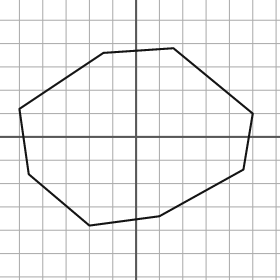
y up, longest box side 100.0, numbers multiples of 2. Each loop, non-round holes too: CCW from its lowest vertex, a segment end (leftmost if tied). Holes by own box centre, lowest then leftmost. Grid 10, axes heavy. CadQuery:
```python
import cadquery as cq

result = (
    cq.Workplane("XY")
    .moveTo(-20.0, -38.0)
    .lineTo(10.0, -34.0)
    .lineTo(46.0, -14.0)
    .lineTo(50.0, 10.0)
    .lineTo(16.0, 38.0)
    .lineTo(-14.0, 36.0)
    .lineTo(-50.0, 12.0)
    .lineTo(-46.0, -16.0)
    .close()
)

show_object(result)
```